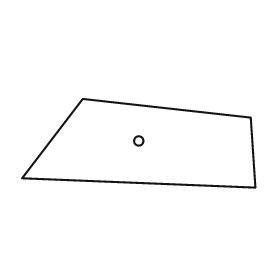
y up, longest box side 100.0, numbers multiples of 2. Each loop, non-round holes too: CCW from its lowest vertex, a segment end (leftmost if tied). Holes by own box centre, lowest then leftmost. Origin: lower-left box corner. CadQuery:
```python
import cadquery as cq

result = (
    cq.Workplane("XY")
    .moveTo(100.0, 0.0)
    .lineTo(98.0, 30.0)
    .lineTo(26.0, 38.0)
    .lineTo(0.0, 4.0)
    .close()
    .moveTo(50.0, 20.0)
    .circle(2.0)
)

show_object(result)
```